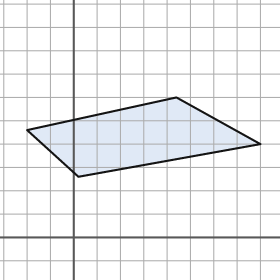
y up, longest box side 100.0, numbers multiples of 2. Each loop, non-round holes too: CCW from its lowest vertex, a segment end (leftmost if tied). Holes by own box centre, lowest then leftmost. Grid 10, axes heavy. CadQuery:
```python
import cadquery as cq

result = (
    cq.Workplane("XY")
    .moveTo(2.0, 26.0)
    .lineTo(80.0, 40.0)
    .lineTo(44.0, 60.0)
    .lineTo(-20.0, 46.0)
    .close()
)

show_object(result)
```